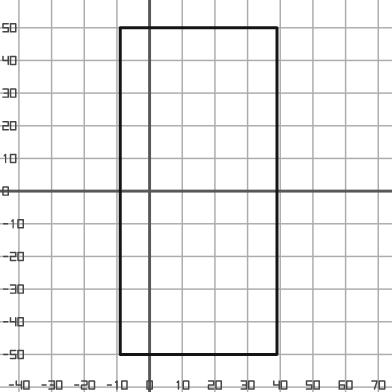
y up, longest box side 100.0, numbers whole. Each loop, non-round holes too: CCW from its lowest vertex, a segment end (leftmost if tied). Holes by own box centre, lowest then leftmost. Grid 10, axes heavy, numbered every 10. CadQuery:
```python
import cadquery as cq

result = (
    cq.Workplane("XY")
    .moveTo(-9.0, -50.0)
    .lineTo(39.0, -50.0)
    .lineTo(39.0, 50.0)
    .lineTo(-9.0, 50.0)
    .close()
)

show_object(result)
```